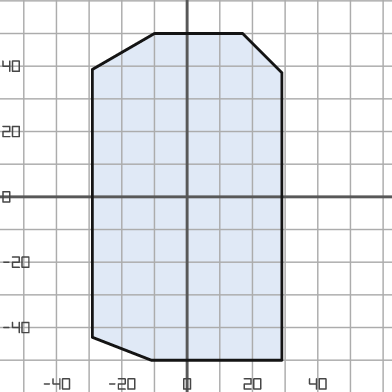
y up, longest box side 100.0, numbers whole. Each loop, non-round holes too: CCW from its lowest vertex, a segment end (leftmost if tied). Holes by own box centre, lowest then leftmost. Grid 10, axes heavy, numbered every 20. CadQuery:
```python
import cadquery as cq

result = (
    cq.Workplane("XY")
    .moveTo(-11.0, -50.0)
    .lineTo(29.0, -50.0)
    .lineTo(29.0, 38.0)
    .lineTo(17.0, 50.0)
    .lineTo(-10.0, 50.0)
    .lineTo(-29.0, 39.0)
    .lineTo(-29.0, -43.0)
    .close()
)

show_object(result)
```